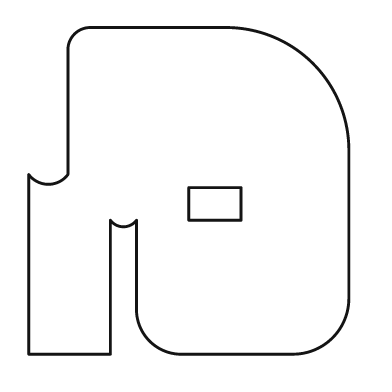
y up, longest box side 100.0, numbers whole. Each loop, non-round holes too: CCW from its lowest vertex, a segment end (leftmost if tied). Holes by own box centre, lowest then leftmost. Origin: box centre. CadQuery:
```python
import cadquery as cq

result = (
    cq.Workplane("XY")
    .moveTo(-49.0, -50.0)
    .lineTo(-24.0, -50.0)
    .lineTo(-24.0, -9.0)
    .threePointArc((-20.0, -11.0), (-16.0, -9.0))
    .lineTo(-16.0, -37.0)
    .threePointArc((-12.0, -46.0), (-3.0, -50.0))
    .lineTo(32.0, -50.0)
    .threePointArc((44.0, -45.0), (49.0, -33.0))
    .lineTo(49.0, 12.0)
    .threePointArc((38.0, 39.0), (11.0, 50.0))
    .lineTo(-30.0, 50.0)
    .threePointArc((-35.0, 48.0), (-37.0, 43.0))
    .lineTo(-37.0, 5.0)
    .threePointArc((-43.0, 2.0), (-49.0, 5.0))
    .close()
    .moveTo(0.0, -9.0)
    .lineTo(16.0, -9.0)
    .lineTo(16.0, 1.0)
    .lineTo(0.0, 1.0)
    .close()
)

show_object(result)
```